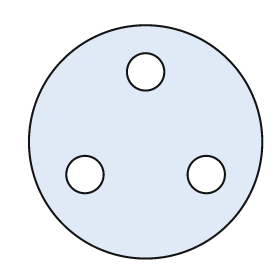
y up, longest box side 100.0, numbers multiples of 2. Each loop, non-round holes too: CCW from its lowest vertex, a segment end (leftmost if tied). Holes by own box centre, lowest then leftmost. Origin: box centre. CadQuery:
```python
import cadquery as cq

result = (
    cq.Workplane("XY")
    .moveTo(0.0, 0.0)
    .circle(50.0)
    .moveTo(-26.0, -14.0)
    .circle(8.0)
    .moveTo(26.0, -14.0)
    .circle(8.0)
    .moveTo(0.0, 30.0)
    .circle(8.0)
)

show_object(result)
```